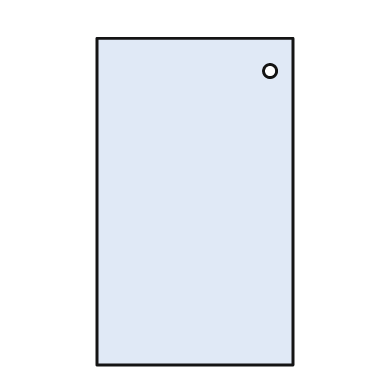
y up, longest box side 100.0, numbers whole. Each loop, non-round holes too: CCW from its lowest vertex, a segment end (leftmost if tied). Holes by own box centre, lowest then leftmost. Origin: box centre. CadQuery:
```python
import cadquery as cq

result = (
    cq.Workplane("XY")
    .moveTo(-30.0, -50.0)
    .lineTo(30.0, -50.0)
    .lineTo(30.0, 50.0)
    .lineTo(-30.0, 50.0)
    .close()
    .moveTo(23.0, 40.0)
    .circle(2.0)
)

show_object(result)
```